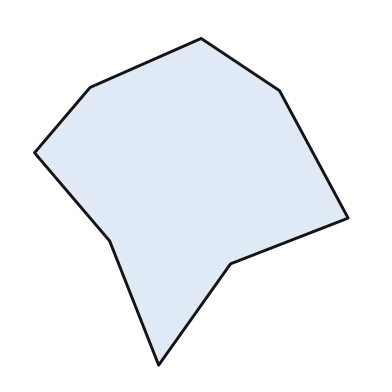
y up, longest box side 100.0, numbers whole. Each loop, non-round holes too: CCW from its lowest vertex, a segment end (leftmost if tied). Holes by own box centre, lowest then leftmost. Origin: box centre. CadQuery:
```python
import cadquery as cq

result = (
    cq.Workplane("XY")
    .moveTo(-10.0, -50.0)
    .lineTo(12.0, -19.0)
    .lineTo(48.0, -5.0)
    .lineTo(27.0, 34.0)
    .lineTo(3.0, 50.0)
    .lineTo(-31.0, 35.0)
    .lineTo(-48.0, 15.0)
    .lineTo(-25.0, -12.0)
    .close()
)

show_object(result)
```